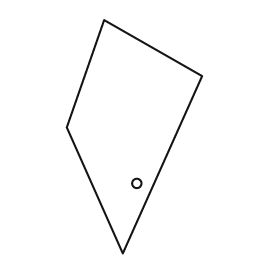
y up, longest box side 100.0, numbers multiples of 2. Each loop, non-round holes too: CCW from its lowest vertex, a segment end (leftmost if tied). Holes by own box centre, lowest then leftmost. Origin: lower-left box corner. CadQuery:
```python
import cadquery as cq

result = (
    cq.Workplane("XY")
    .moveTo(24.0, 0.0)
    .lineTo(58.0, 76.0)
    .lineTo(16.0, 100.0)
    .lineTo(0.0, 54.0)
    .close()
    .moveTo(30.0, 30.0)
    .circle(2.0)
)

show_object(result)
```